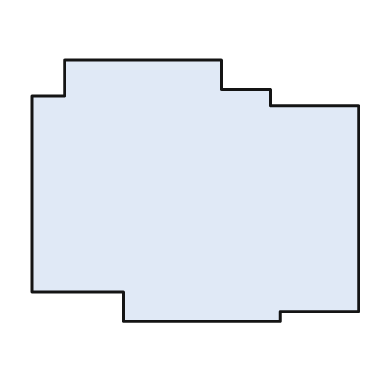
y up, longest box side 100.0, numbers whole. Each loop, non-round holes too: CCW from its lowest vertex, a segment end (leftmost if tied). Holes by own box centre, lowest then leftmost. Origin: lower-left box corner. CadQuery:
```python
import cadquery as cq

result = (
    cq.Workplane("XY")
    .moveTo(28.0, 0.0)
    .lineTo(76.0, 0.0)
    .lineTo(76.0, 3.0)
    .lineTo(100.0, 3.0)
    .lineTo(100.0, 66.0)
    .lineTo(73.0, 66.0)
    .lineTo(73.0, 71.0)
    .lineTo(58.0, 71.0)
    .lineTo(58.0, 80.0)
    .lineTo(10.0, 80.0)
    .lineTo(10.0, 69.0)
    .lineTo(0.0, 69.0)
    .lineTo(0.0, 9.0)
    .lineTo(28.0, 9.0)
    .close()
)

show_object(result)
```